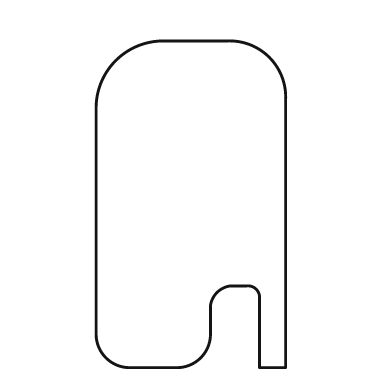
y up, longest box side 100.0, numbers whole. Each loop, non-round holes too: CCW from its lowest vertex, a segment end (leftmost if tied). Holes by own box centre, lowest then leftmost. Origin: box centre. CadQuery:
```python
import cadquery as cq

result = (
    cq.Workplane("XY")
    .moveTo(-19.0, -50.0)
    .lineTo(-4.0, -50.0)
    .threePointArc((3.0, -47.0), (6.0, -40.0))
    .lineTo(6.0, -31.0)
    .threePointArc((8.0, -27.0), (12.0, -25.0))
    .lineTo(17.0, -25.0)
    .threePointArc((20.0, -26.0), (21.0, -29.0))
    .lineTo(21.0, -50.0)
    .lineTo(29.0, -50.0)
    .lineTo(29.0, 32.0)
    .threePointArc((24.0, 45.0), (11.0, 50.0))
    .lineTo(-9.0, 50.0)
    .threePointArc((-23.0, 44.0), (-29.0, 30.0))
    .lineTo(-29.0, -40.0)
    .threePointArc((-26.0, -47.0), (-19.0, -50.0))
    .close()
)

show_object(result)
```